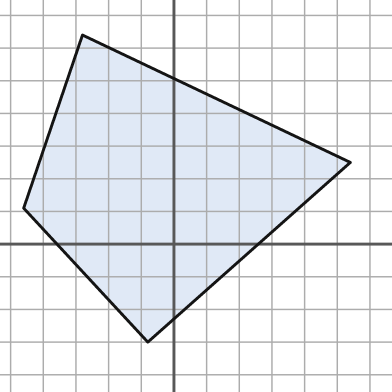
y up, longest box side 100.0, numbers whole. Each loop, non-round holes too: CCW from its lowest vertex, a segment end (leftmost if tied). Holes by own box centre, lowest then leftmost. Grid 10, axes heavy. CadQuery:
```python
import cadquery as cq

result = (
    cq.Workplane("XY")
    .moveTo(-8.0, -30.0)
    .lineTo(54.0, 25.0)
    .lineTo(-28.0, 64.0)
    .lineTo(-46.0, 11.0)
    .close()
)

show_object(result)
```